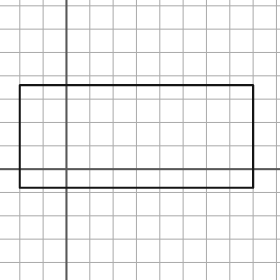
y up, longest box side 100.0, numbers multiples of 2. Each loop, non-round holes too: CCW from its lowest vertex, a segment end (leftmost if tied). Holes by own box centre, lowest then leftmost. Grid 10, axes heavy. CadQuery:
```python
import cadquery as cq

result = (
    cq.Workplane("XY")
    .moveTo(-20.0, -8.0)
    .lineTo(80.0, -8.0)
    .lineTo(80.0, 36.0)
    .lineTo(-20.0, 36.0)
    .close()
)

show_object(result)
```